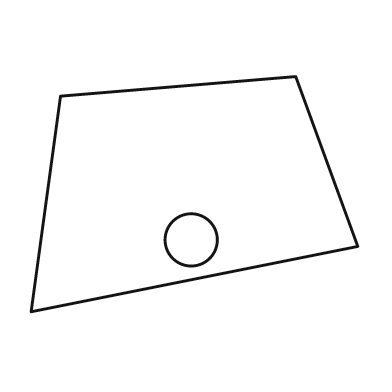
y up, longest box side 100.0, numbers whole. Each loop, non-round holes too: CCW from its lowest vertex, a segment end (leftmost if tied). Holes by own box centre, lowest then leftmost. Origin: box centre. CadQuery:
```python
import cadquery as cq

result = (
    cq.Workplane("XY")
    .moveTo(-50.0, -36.0)
    .lineTo(50.0, -16.0)
    .lineTo(31.0, 36.0)
    .lineTo(-41.0, 30.0)
    .close()
    .moveTo(-1.0, -14.0)
    .circle(8.0)
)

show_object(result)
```